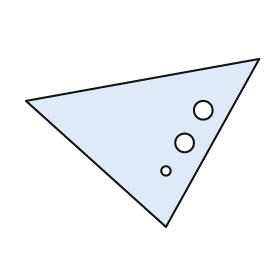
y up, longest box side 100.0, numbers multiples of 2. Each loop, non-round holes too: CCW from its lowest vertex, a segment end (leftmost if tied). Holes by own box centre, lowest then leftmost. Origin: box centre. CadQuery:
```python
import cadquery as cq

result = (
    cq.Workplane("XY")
    .moveTo(10.0, -36.0)
    .lineTo(50.0, 36.0)
    .lineTo(-50.0, 18.0)
    .close()
    .moveTo(10.0, -12.0)
    .circle(2.0)
    .moveTo(18.0, 0.0)
    .circle(4.0)
    .moveTo(26.0, 14.0)
    .circle(4.0)
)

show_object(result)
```